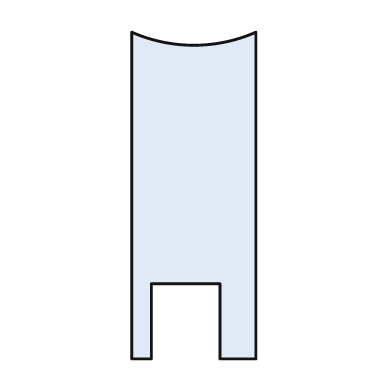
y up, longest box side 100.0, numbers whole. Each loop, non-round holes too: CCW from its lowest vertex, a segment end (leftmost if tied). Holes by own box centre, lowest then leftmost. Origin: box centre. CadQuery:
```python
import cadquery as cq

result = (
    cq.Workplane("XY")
    .moveTo(-19.0, -50.0)
    .lineTo(-13.0, -50.0)
    .lineTo(-13.0, -27.0)
    .lineTo(8.0, -27.0)
    .lineTo(8.0, -50.0)
    .lineTo(19.0, -50.0)
    .lineTo(19.0, 50.0)
    .threePointArc((0.0, 46.0), (-19.0, 50.0))
    .close()
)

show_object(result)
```